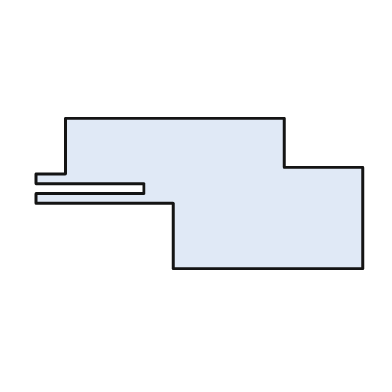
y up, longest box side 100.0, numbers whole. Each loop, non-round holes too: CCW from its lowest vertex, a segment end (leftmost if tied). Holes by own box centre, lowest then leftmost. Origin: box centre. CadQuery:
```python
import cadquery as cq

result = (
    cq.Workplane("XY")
    .moveTo(-8.0, -23.0)
    .lineTo(50.0, -23.0)
    .lineTo(50.0, 8.0)
    .lineTo(26.0, 8.0)
    .lineTo(26.0, 23.0)
    .lineTo(-41.0, 23.0)
    .lineTo(-41.0, 6.0)
    .lineTo(-50.0, 6.0)
    .lineTo(-50.0, 3.0)
    .lineTo(-17.0, 3.0)
    .lineTo(-17.0, 0.0)
    .lineTo(-50.0, 0.0)
    .lineTo(-50.0, -3.0)
    .lineTo(-8.0, -3.0)
    .close()
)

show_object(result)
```